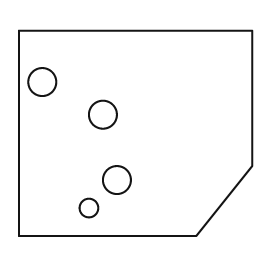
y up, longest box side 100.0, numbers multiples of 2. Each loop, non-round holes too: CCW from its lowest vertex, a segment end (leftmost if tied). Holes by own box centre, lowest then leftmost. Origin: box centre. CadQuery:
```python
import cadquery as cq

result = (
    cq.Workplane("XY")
    .moveTo(-50.0, -44.0)
    .lineTo(26.0, -44.0)
    .lineTo(50.0, -14.0)
    .lineTo(50.0, 44.0)
    .lineTo(-50.0, 44.0)
    .close()
    .moveTo(-20.0, -32.0)
    .circle(4.0)
    .moveTo(-8.0, -20.0)
    .circle(6.0)
    .moveTo(-14.0, 8.0)
    .circle(6.0)
    .moveTo(-40.0, 22.0)
    .circle(6.0)
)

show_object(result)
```